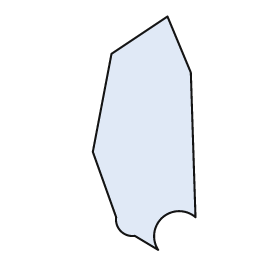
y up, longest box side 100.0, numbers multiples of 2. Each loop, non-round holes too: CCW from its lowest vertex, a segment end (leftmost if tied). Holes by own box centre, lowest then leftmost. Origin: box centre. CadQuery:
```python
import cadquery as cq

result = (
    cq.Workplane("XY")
    .moveTo(6.0, -50.0)
    .threePointArc((8.0, -36.0), (22.0, -36.0))
    .lineTo(20.0, 26.0)
    .lineTo(10.0, 50.0)
    .lineTo(-14.0, 34.0)
    .lineTo(-22.0, -8.0)
    .lineTo(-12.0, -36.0)
    .threePointArc((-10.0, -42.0), (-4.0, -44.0))
    .close()
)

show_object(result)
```